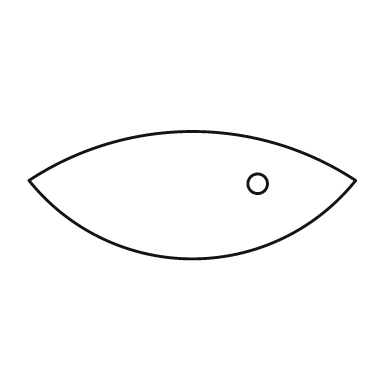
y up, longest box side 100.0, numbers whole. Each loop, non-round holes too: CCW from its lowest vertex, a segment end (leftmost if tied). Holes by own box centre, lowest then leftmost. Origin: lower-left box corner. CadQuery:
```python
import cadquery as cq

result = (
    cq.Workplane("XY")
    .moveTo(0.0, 24.0)
    .threePointArc((50.0, 0.0), (100.0, 24.0))
    .threePointArc((50.0, 39.0), (0.0, 24.0))
    .close()
    .moveTo(70.0, 23.0)
    .circle(3.0)
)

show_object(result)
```